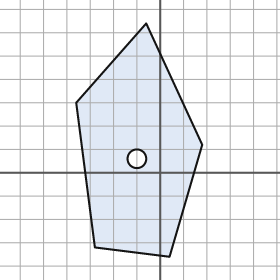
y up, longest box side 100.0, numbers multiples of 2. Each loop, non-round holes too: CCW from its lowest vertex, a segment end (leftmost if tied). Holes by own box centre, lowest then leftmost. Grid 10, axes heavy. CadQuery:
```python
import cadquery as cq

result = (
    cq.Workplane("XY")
    .moveTo(4.0, -36.0)
    .lineTo(18.0, 12.0)
    .lineTo(-6.0, 64.0)
    .lineTo(-36.0, 30.0)
    .lineTo(-28.0, -32.0)
    .close()
    .moveTo(-10.0, 6.0)
    .circle(4.0)
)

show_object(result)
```